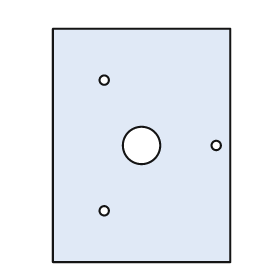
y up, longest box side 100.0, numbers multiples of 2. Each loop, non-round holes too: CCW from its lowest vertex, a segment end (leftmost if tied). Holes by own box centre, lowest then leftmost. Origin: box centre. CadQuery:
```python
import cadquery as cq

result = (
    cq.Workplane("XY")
    .moveTo(-38.0, -50.0)
    .lineTo(38.0, -50.0)
    .lineTo(38.0, 50.0)
    .lineTo(-38.0, 50.0)
    .close()
    .moveTo(-16.0, -28.0)
    .circle(2.0)
    .moveTo(0.0, 0.0)
    .circle(8.0)
    .moveTo(32.0, 0.0)
    .circle(2.0)
    .moveTo(-16.0, 28.0)
    .circle(2.0)
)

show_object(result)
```